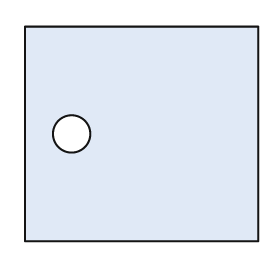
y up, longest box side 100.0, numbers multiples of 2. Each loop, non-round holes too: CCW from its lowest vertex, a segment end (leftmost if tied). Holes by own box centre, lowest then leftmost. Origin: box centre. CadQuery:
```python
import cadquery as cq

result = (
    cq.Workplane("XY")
    .moveTo(-50.0, -46.0)
    .lineTo(50.0, -46.0)
    .lineTo(50.0, 46.0)
    .lineTo(-50.0, 46.0)
    .close()
    .moveTo(-30.0, 0.0)
    .circle(8.0)
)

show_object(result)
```